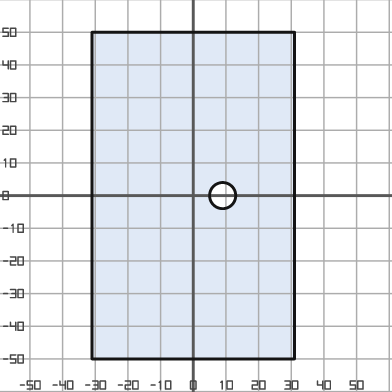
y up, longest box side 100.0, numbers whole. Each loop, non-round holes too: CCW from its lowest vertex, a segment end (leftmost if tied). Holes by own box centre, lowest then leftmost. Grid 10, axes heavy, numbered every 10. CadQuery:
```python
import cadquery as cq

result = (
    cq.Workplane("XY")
    .moveTo(-31.0, -50.0)
    .lineTo(31.0, -50.0)
    .lineTo(31.0, 50.0)
    .lineTo(-31.0, 50.0)
    .close()
    .moveTo(9.0, 0.0)
    .circle(4.0)
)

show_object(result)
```